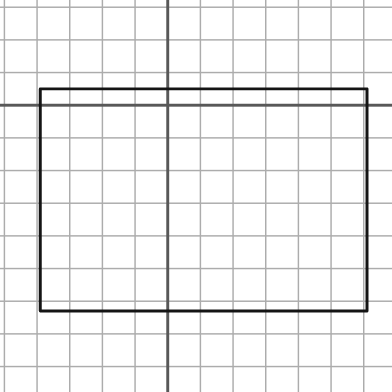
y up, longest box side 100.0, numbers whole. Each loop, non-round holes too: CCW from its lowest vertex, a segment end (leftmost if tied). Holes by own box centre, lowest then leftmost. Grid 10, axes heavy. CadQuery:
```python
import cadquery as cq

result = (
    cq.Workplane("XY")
    .moveTo(-39.0, -63.0)
    .lineTo(61.0, -63.0)
    .lineTo(61.0, 5.0)
    .lineTo(-39.0, 5.0)
    .close()
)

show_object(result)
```